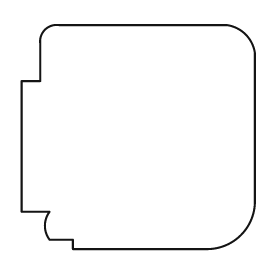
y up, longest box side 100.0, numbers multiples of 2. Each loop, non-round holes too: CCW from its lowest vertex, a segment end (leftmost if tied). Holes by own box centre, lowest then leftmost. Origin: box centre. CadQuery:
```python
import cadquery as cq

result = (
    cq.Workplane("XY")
    .moveTo(-28.0, -48.0)
    .lineTo(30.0, -48.0)
    .threePointArc((44.0, -42.0), (50.0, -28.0))
    .lineTo(50.0, 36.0)
    .threePointArc((46.0, 44.0), (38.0, 48.0))
    .lineTo(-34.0, 48.0)
    .threePointArc((-40.0, 46.0), (-42.0, 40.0))
    .lineTo(-42.0, 24.0)
    .lineTo(-50.0, 24.0)
    .lineTo(-50.0, -32.0)
    .lineTo(-38.0, -32.0)
    .threePointArc((-40.0, -38.0), (-38.0, -44.0))
    .lineTo(-28.0, -44.0)
    .close()
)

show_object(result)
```